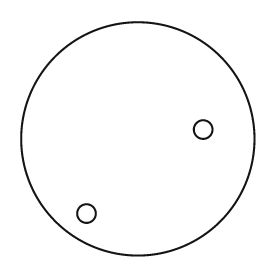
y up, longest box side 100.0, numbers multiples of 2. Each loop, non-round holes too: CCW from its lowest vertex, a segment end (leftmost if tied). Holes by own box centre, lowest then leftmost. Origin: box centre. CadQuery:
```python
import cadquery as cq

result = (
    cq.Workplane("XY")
    .moveTo(0.0, 0.0)
    .circle(50.0)
    .moveTo(-22.0, -32.0)
    .circle(4.0)
    .moveTo(28.0, 4.0)
    .circle(4.0)
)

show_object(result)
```